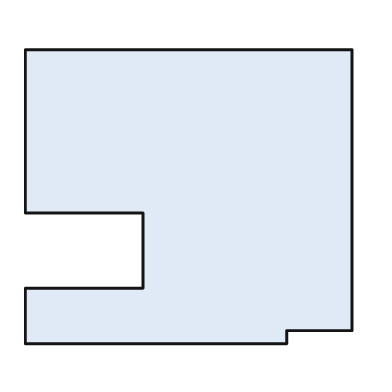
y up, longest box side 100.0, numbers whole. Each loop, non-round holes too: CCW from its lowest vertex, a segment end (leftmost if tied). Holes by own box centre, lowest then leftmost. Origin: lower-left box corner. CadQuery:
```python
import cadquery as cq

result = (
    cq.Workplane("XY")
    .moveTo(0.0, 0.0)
    .lineTo(80.0, 0.0)
    .lineTo(80.0, 4.0)
    .lineTo(100.0, 4.0)
    .lineTo(100.0, 90.0)
    .lineTo(0.0, 90.0)
    .lineTo(0.0, 40.0)
    .lineTo(36.0, 40.0)
    .lineTo(36.0, 17.0)
    .lineTo(0.0, 17.0)
    .close()
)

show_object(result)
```